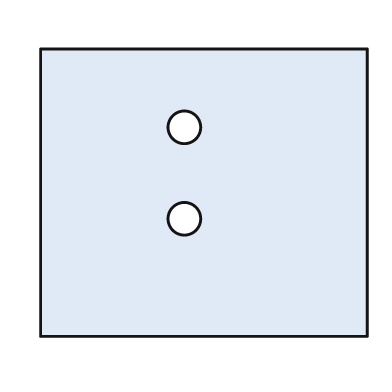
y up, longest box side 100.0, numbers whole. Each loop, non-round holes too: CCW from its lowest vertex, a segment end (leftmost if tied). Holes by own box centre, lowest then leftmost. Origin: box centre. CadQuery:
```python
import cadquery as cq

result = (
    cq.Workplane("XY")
    .moveTo(-50.0, -44.0)
    .lineTo(50.0, -44.0)
    .lineTo(50.0, 44.0)
    .lineTo(-50.0, 44.0)
    .close()
    .moveTo(-6.0, -8.0)
    .circle(5.0)
    .moveTo(-6.0, 20.0)
    .circle(5.0)
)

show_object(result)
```